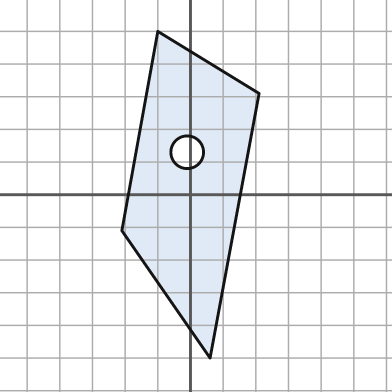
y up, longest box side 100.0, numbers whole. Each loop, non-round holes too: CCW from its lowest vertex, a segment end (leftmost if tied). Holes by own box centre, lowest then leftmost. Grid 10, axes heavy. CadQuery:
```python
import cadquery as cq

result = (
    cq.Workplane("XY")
    .moveTo(6.0, -50.0)
    .lineTo(21.0, 31.0)
    .lineTo(-10.0, 50.0)
    .lineTo(-21.0, -11.0)
    .close()
    .moveTo(-1.0, 13.0)
    .circle(5.0)
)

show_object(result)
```